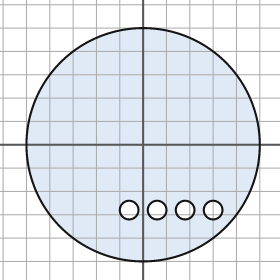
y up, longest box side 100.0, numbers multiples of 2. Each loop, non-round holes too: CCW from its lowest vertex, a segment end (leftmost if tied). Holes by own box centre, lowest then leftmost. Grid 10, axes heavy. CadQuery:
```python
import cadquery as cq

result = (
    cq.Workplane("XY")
    .moveTo(0.0, 0.0)
    .circle(50.0)
    .moveTo(-6.0, -28.0)
    .circle(4.0)
    .moveTo(6.0, -28.0)
    .circle(4.0)
    .moveTo(18.0, -28.0)
    .circle(4.0)
    .moveTo(30.0, -28.0)
    .circle(4.0)
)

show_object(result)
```